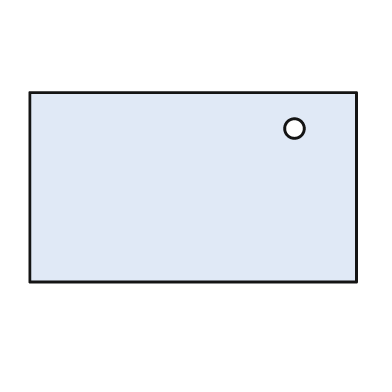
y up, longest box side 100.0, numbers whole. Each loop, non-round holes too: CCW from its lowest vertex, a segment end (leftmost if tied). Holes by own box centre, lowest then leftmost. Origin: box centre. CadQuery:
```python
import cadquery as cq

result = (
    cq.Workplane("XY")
    .moveTo(-50.0, -29.0)
    .lineTo(50.0, -29.0)
    .lineTo(50.0, 29.0)
    .lineTo(-50.0, 29.0)
    .close()
    .moveTo(31.0, 18.0)
    .circle(3.0)
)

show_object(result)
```